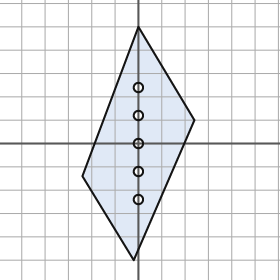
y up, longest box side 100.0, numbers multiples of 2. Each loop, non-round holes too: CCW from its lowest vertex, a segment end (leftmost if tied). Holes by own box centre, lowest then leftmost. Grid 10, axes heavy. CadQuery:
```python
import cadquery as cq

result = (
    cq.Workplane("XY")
    .moveTo(-2.0, -50.0)
    .lineTo(24.0, 10.0)
    .lineTo(0.0, 50.0)
    .lineTo(-24.0, -14.0)
    .close()
    .moveTo(0.0, -24.0)
    .circle(2.0)
    .moveTo(0.0, -12.0)
    .circle(2.0)
    .moveTo(0.0, 0.0)
    .circle(2.0)
    .moveTo(0.0, 12.0)
    .circle(2.0)
    .moveTo(0.0, 24.0)
    .circle(2.0)
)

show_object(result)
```